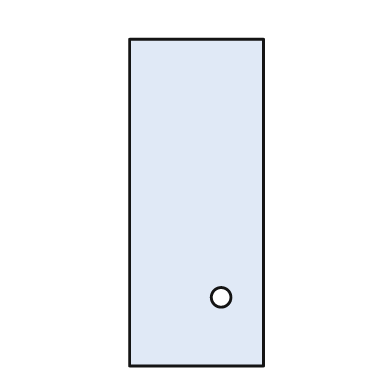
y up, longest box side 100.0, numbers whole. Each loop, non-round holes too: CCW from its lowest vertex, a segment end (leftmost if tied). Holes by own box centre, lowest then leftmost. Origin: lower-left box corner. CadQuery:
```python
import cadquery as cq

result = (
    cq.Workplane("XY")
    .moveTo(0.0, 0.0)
    .lineTo(41.0, 0.0)
    .lineTo(41.0, 100.0)
    .lineTo(0.0, 100.0)
    .close()
    .moveTo(28.0, 21.0)
    .circle(3.0)
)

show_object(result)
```